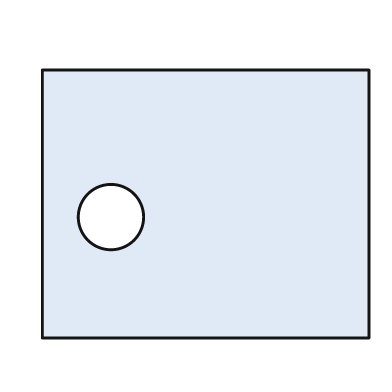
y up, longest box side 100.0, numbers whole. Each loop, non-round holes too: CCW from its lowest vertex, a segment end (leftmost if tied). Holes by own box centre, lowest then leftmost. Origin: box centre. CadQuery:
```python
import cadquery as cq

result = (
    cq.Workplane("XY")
    .moveTo(-50.0, -41.0)
    .lineTo(50.0, -41.0)
    .lineTo(50.0, 41.0)
    .lineTo(-50.0, 41.0)
    .close()
    .moveTo(-29.0, -4.0)
    .circle(10.0)
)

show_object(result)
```